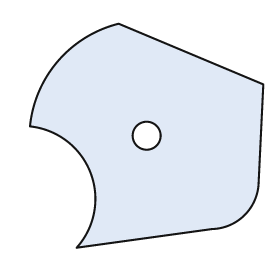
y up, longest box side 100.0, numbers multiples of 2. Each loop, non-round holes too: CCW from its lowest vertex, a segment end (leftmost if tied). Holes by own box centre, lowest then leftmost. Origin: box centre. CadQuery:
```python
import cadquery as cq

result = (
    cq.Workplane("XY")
    .moveTo(-30.0, -48.0)
    .lineTo(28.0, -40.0)
    .threePointArc((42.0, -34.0), (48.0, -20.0))
    .lineTo(50.0, 22.0)
    .lineTo(-12.0, 48.0)
    .threePointArc((-38.0, 32.0), (-50.0, 4.0))
    .threePointArc((-24.0, -16.0), (-30.0, -48.0))
    .close()
    .moveTo(0.0, 0.0)
    .circle(6.0)
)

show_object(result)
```